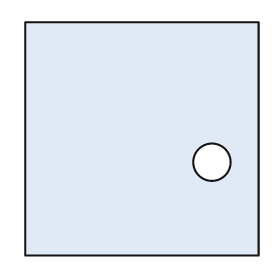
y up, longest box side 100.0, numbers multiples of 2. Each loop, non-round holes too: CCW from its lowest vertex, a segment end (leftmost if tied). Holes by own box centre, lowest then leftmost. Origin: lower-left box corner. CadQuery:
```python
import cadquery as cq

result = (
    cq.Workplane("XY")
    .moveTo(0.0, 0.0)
    .lineTo(100.0, 0.0)
    .lineTo(100.0, 100.0)
    .lineTo(0.0, 100.0)
    .close()
    .moveTo(80.0, 40.0)
    .circle(8.0)
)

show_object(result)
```